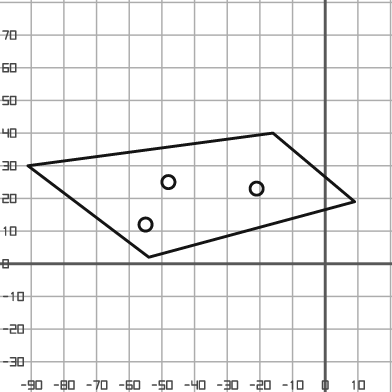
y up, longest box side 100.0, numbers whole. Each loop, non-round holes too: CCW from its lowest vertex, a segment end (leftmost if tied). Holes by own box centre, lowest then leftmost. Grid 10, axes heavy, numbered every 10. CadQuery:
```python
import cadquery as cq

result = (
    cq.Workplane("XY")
    .moveTo(-54.0, 2.0)
    .lineTo(9.0, 19.0)
    .lineTo(-16.0, 40.0)
    .lineTo(-91.0, 30.0)
    .close()
    .moveTo(-55.0, 12.0)
    .circle(2.0)
    .moveTo(-21.0, 23.0)
    .circle(2.0)
    .moveTo(-48.0, 25.0)
    .circle(2.0)
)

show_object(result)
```